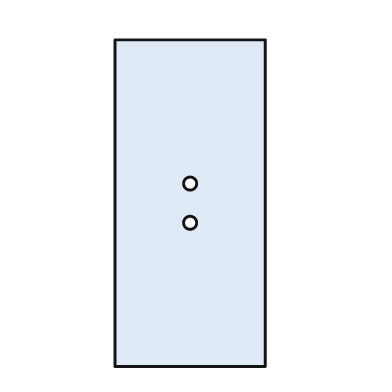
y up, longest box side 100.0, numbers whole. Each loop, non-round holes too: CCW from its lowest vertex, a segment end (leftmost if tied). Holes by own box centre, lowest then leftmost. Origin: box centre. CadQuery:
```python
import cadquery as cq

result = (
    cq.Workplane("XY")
    .moveTo(-23.0, -50.0)
    .lineTo(23.0, -50.0)
    .lineTo(23.0, 50.0)
    .lineTo(-23.0, 50.0)
    .close()
    .moveTo(0.0, -6.0)
    .circle(2.0)
    .moveTo(0.0, 6.0)
    .circle(2.0)
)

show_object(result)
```